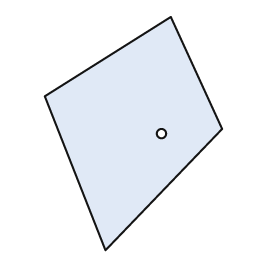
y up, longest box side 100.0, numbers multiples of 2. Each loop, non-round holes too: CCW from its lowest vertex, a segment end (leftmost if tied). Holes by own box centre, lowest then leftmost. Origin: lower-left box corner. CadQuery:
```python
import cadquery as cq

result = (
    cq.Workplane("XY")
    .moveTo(26.0, 0.0)
    .lineTo(76.0, 52.0)
    .lineTo(54.0, 100.0)
    .lineTo(0.0, 66.0)
    .close()
    .moveTo(50.0, 50.0)
    .circle(2.0)
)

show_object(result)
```